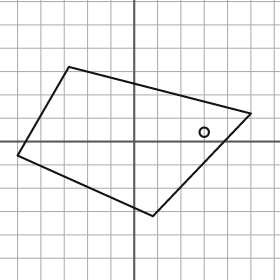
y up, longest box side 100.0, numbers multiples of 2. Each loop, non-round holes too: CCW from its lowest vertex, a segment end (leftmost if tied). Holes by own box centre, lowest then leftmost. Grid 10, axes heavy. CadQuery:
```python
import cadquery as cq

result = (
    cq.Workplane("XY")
    .moveTo(8.0, -32.0)
    .lineTo(50.0, 12.0)
    .lineTo(-28.0, 32.0)
    .lineTo(-50.0, -6.0)
    .close()
    .moveTo(30.0, 4.0)
    .circle(2.0)
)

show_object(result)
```